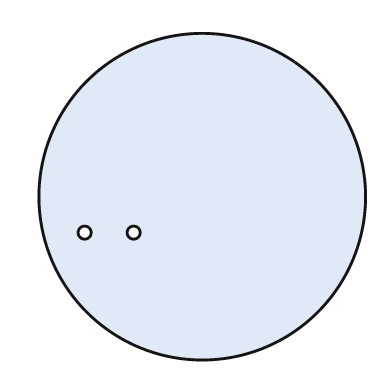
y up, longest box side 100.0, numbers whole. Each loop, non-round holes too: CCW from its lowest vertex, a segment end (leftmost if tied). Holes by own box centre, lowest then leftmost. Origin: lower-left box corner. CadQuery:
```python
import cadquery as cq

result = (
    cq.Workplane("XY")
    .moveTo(50.0, 50.0)
    .circle(50.0)
    .moveTo(14.0, 39.0)
    .circle(2.0)
    .moveTo(29.0, 39.0)
    .circle(2.0)
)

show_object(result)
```